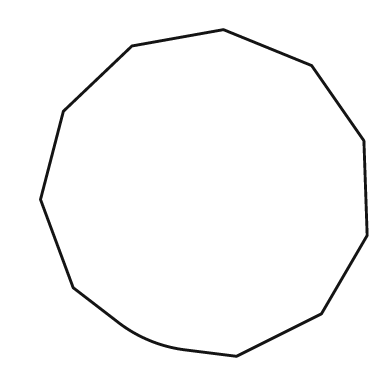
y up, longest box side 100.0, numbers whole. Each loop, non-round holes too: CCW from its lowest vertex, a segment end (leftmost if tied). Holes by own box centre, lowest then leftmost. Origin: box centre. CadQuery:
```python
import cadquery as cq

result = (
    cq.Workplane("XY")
    .moveTo(10.0, -50.0)
    .lineTo(36.0, -37.0)
    .lineTo(50.0, -13.0)
    .lineTo(49.0, 16.0)
    .lineTo(33.0, 39.0)
    .lineTo(6.0, 50.0)
    .lineTo(-22.0, 45.0)
    .lineTo(-43.0, 25.0)
    .lineTo(-50.0, -2.0)
    .lineTo(-40.0, -29.0)
    .lineTo(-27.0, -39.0)
    .threePointArc((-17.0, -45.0), (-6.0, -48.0))
    .close()
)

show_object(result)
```